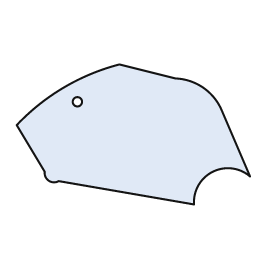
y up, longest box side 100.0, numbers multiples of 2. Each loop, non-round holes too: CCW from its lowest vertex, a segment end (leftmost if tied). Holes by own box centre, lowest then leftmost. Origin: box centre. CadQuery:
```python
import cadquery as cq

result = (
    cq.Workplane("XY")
    .moveTo(26.0, -30.0)
    .threePointArc((34.0, -16.0), (50.0, -18.0))
    .lineTo(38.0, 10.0)
    .threePointArc((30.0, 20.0), (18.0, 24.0))
    .lineTo(-6.0, 30.0)
    .threePointArc((-30.0, 20.0), (-50.0, 4.0))
    .lineTo(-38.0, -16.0)
    .threePointArc((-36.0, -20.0), (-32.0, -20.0))
    .close()
    .moveTo(-24.0, 14.0)
    .circle(2.0)
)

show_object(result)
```